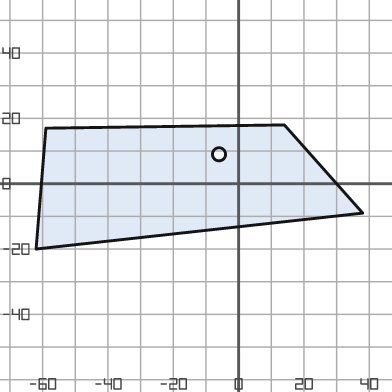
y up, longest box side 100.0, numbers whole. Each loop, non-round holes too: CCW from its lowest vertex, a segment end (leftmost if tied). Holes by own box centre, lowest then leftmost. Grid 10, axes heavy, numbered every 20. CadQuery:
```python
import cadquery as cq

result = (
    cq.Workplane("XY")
    .moveTo(-62.0, -20.0)
    .lineTo(38.0, -9.0)
    .lineTo(14.0, 18.0)
    .lineTo(-59.0, 17.0)
    .close()
    .moveTo(-6.0, 9.0)
    .circle(2.0)
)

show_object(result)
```